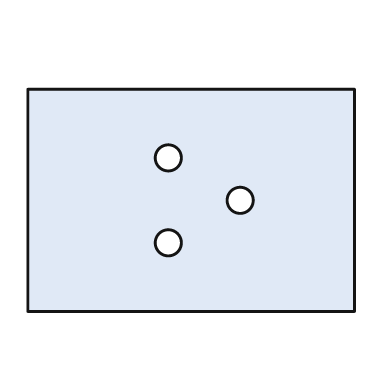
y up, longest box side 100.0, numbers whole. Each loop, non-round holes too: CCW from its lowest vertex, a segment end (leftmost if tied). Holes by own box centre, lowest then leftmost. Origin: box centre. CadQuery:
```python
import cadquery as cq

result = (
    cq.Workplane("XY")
    .moveTo(-50.0, -34.0)
    .lineTo(50.0, -34.0)
    .lineTo(50.0, 34.0)
    .lineTo(-50.0, 34.0)
    .close()
    .moveTo(-7.0, -13.0)
    .circle(4.0)
    .moveTo(15.0, 0.0)
    .circle(4.0)
    .moveTo(-7.0, 13.0)
    .circle(4.0)
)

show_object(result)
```